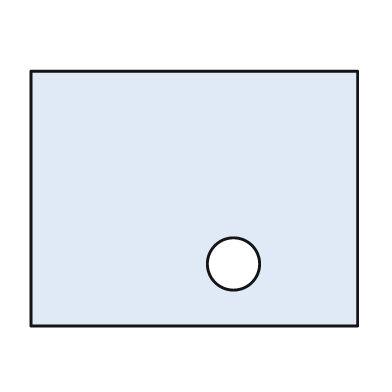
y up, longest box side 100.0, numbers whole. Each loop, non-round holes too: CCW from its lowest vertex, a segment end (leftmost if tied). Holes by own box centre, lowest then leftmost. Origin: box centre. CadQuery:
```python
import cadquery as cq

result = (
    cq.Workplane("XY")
    .moveTo(-50.0, -39.0)
    .lineTo(50.0, -39.0)
    .lineTo(50.0, 39.0)
    .lineTo(-50.0, 39.0)
    .close()
    .moveTo(12.0, -20.0)
    .circle(8.0)
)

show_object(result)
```